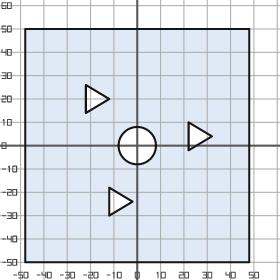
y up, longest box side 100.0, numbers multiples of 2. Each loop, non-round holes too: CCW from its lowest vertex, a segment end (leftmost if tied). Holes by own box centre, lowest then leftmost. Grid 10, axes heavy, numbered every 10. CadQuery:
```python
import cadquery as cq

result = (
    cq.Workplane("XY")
    .moveTo(-48.0, -50.0)
    .lineTo(48.0, -50.0)
    .lineTo(48.0, 50.0)
    .lineTo(-48.0, 50.0)
    .close()
    .moveTo(-12.0, -30.0)
    .lineTo(-2.0, -24.0)
    .lineTo(-12.0, -18.0)
    .close()
    .moveTo(0.0, 0.0)
    .circle(8.0)
    .moveTo(22.0, -2.0)
    .lineTo(32.0, 4.0)
    .lineTo(22.0, 10.0)
    .close()
    .moveTo(-22.0, 14.0)
    .lineTo(-12.0, 20.0)
    .lineTo(-22.0, 26.0)
    .close()
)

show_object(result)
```